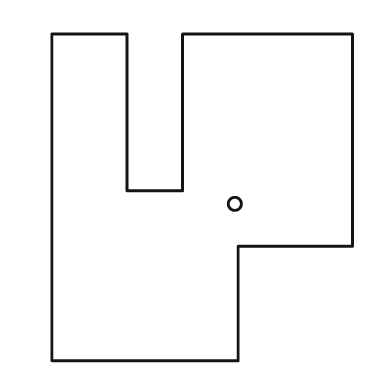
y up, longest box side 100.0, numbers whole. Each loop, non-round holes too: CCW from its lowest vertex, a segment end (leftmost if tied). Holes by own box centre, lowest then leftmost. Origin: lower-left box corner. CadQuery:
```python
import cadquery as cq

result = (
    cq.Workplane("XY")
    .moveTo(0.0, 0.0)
    .lineTo(57.0, 0.0)
    .lineTo(57.0, 35.0)
    .lineTo(92.0, 35.0)
    .lineTo(92.0, 100.0)
    .lineTo(40.0, 100.0)
    .lineTo(40.0, 52.0)
    .lineTo(23.0, 52.0)
    .lineTo(23.0, 100.0)
    .lineTo(0.0, 100.0)
    .close()
    .moveTo(56.0, 48.0)
    .circle(2.0)
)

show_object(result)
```